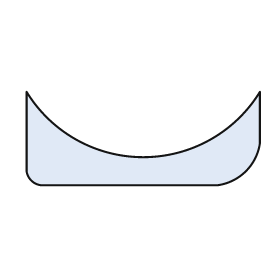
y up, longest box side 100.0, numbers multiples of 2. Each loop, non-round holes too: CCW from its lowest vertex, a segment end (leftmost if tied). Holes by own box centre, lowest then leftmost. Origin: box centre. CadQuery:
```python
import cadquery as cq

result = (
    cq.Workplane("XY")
    .moveTo(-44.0, -20.0)
    .lineTo(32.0, -20.0)
    .threePointArc((44.0, -14.0), (50.0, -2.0))
    .lineTo(50.0, 20.0)
    .threePointArc((0.0, -8.0), (-50.0, 20.0))
    .lineTo(-50.0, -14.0)
    .threePointArc((-48.0, -18.0), (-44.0, -20.0))
    .close()
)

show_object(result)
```